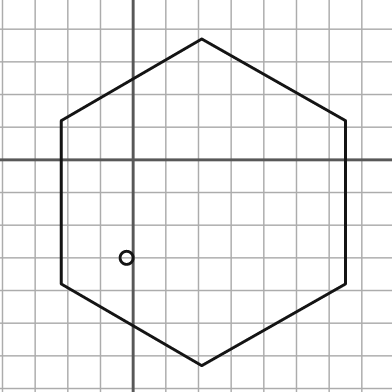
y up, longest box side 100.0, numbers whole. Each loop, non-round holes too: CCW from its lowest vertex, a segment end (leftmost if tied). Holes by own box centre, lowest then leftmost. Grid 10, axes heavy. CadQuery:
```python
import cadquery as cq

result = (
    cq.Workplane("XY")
    .moveTo(21.0, -63.0)
    .lineTo(65.0, -38.0)
    .lineTo(65.0, 12.0)
    .lineTo(21.0, 37.0)
    .lineTo(-22.0, 12.0)
    .lineTo(-22.0, -38.0)
    .close()
    .moveTo(-2.0, -30.0)
    .circle(2.0)
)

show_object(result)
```